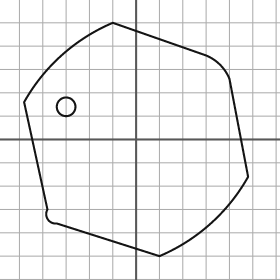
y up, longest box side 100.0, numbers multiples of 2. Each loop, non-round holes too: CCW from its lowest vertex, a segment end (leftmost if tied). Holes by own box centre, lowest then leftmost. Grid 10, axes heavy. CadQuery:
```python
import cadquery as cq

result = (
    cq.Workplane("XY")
    .moveTo(10.0, -50.0)
    .threePointArc((32.0, -36.0), (48.0, -16.0))
    .lineTo(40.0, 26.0)
    .threePointArc((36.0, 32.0), (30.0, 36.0))
    .lineTo(-10.0, 50.0)
    .threePointArc((-32.0, 36.0), (-48.0, 16.0))
    .lineTo(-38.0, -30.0)
    .threePointArc((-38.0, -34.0), (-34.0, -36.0))
    .close()
    .moveTo(-30.0, 14.0)
    .circle(4.0)
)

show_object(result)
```